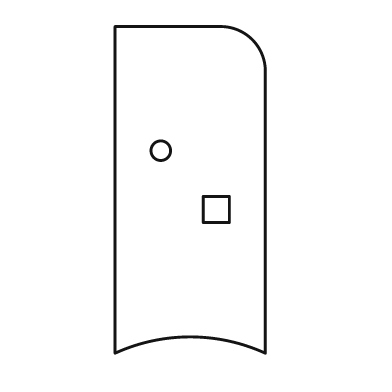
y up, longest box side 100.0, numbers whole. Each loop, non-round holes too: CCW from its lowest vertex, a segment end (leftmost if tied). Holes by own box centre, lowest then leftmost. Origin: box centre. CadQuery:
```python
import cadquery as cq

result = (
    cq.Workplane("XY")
    .moveTo(-23.0, -50.0)
    .threePointArc((0.0, -45.0), (23.0, -50.0))
    .lineTo(23.0, 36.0)
    .threePointArc((19.0, 46.0), (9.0, 50.0))
    .lineTo(-23.0, 50.0)
    .close()
    .moveTo(4.0, -10.0)
    .lineTo(12.0, -10.0)
    .lineTo(12.0, -2.0)
    .lineTo(4.0, -2.0)
    .close()
    .moveTo(-9.0, 12.0)
    .circle(3.0)
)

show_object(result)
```